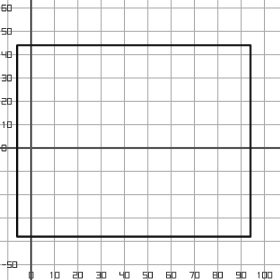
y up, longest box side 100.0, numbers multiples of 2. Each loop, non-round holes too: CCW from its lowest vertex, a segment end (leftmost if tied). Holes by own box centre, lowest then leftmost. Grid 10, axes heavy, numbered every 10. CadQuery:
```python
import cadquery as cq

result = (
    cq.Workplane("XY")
    .moveTo(-6.0, -38.0)
    .lineTo(94.0, -38.0)
    .lineTo(94.0, 44.0)
    .lineTo(-6.0, 44.0)
    .close()
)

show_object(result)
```